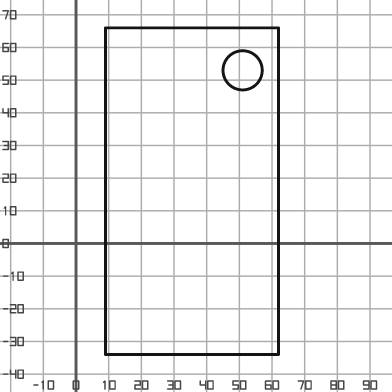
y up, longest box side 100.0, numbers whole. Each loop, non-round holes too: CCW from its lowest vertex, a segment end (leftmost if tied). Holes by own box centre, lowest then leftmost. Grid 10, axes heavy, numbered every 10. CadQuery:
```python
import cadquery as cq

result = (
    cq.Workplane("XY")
    .moveTo(9.0, -34.0)
    .lineTo(62.0, -34.0)
    .lineTo(62.0, 66.0)
    .lineTo(9.0, 66.0)
    .close()
    .moveTo(51.0, 53.0)
    .circle(6.0)
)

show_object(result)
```